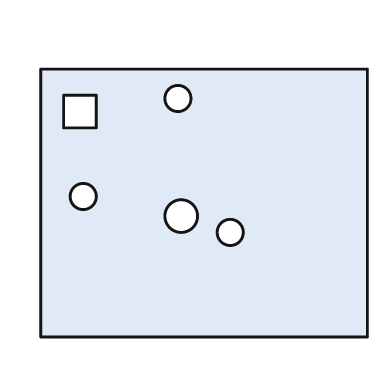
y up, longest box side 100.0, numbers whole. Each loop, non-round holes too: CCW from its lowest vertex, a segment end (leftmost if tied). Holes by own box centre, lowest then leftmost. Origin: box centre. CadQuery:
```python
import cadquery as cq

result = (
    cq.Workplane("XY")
    .moveTo(-50.0, -41.0)
    .lineTo(50.0, -41.0)
    .lineTo(50.0, 41.0)
    .lineTo(-50.0, 41.0)
    .close()
    .moveTo(8.0, -9.0)
    .circle(4.0)
    .moveTo(-7.0, -4.0)
    .circle(5.0)
    .moveTo(-37.0, 2.0)
    .circle(4.0)
    .moveTo(-43.0, 23.0)
    .lineTo(-33.0, 23.0)
    .lineTo(-33.0, 33.0)
    .lineTo(-43.0, 33.0)
    .close()
    .moveTo(-8.0, 32.0)
    .circle(4.0)
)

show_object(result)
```